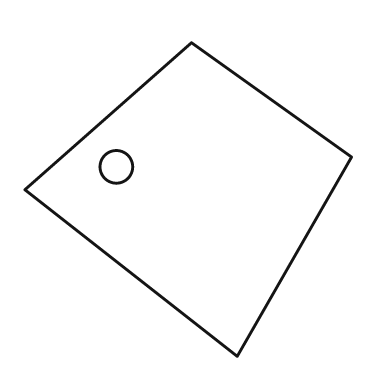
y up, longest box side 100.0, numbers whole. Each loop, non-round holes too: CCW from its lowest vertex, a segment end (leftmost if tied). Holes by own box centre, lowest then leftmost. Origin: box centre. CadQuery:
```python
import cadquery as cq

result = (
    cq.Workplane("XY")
    .moveTo(15.0, -48.0)
    .lineTo(50.0, 13.0)
    .lineTo(1.0, 48.0)
    .lineTo(-50.0, 3.0)
    .close()
    .moveTo(-22.0, 10.0)
    .circle(5.0)
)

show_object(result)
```